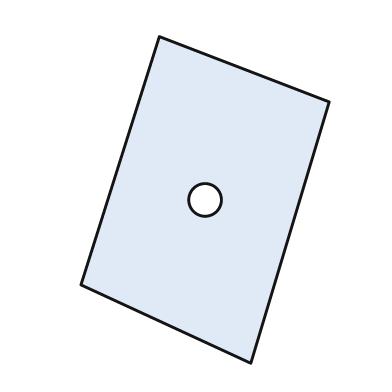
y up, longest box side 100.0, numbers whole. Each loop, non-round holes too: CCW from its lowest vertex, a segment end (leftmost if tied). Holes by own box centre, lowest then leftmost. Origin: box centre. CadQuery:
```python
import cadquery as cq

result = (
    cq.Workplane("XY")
    .moveTo(14.0, -50.0)
    .lineTo(38.0, 30.0)
    .lineTo(-14.0, 50.0)
    .lineTo(-38.0, -26.0)
    .close()
    .moveTo(0.0, 0.0)
    .circle(5.0)
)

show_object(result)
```